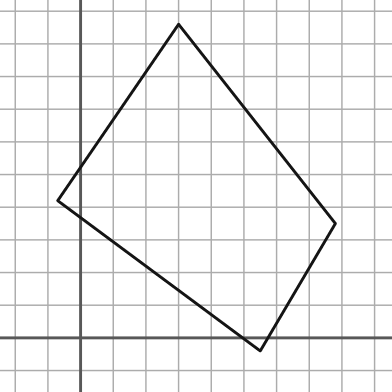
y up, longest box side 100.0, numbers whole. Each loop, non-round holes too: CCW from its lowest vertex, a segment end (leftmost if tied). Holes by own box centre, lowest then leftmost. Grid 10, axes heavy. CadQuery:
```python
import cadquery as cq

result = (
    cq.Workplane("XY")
    .moveTo(55.0, -4.0)
    .lineTo(78.0, 35.0)
    .lineTo(30.0, 96.0)
    .lineTo(-7.0, 42.0)
    .close()
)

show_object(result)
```